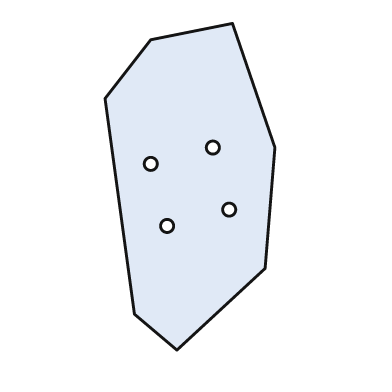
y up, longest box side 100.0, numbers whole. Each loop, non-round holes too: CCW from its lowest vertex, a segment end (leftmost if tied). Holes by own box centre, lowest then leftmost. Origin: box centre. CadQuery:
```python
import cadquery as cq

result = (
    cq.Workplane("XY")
    .moveTo(-4.0, -50.0)
    .lineTo(23.0, -25.0)
    .lineTo(26.0, 12.0)
    .lineTo(13.0, 50.0)
    .lineTo(-12.0, 45.0)
    .lineTo(-26.0, 27.0)
    .lineTo(-17.0, -39.0)
    .close()
    .moveTo(-7.0, -12.0)
    .circle(2.0)
    .moveTo(12.0, -7.0)
    .circle(2.0)
    .moveTo(-12.0, 7.0)
    .circle(2.0)
    .moveTo(7.0, 12.0)
    .circle(2.0)
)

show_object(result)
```